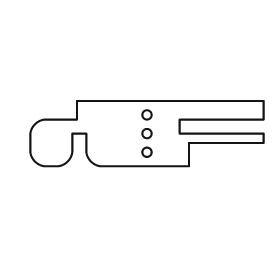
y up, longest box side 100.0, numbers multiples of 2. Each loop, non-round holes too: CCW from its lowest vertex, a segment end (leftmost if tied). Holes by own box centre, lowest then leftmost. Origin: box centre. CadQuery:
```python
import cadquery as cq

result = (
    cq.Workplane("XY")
    .moveTo(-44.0, -14.0)
    .lineTo(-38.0, -14.0)
    .threePointArc((-34.0, -12.0), (-32.0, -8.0))
    .lineTo(-32.0, 0.0)
    .lineTo(-26.0, 0.0)
    .lineTo(-26.0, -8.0)
    .threePointArc((-24.0, -12.0), (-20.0, -14.0))
    .lineTo(18.0, -14.0)
    .lineTo(18.0, -4.0)
    .lineTo(50.0, -4.0)
    .lineTo(50.0, 0.0)
    .lineTo(14.0, 0.0)
    .lineTo(14.0, 6.0)
    .lineTo(50.0, 6.0)
    .lineTo(50.0, 14.0)
    .lineTo(-30.0, 14.0)
    .lineTo(-30.0, 6.0)
    .lineTo(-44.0, 6.0)
    .threePointArc((-48.0, 4.0), (-50.0, 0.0))
    .lineTo(-50.0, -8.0)
    .threePointArc((-48.0, -12.0), (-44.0, -14.0))
    .close()
    .moveTo(0.0, -8.0)
    .circle(2.0)
    .moveTo(0.0, 0.0)
    .circle(2.0)
    .moveTo(0.0, 8.0)
    .circle(2.0)
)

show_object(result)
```